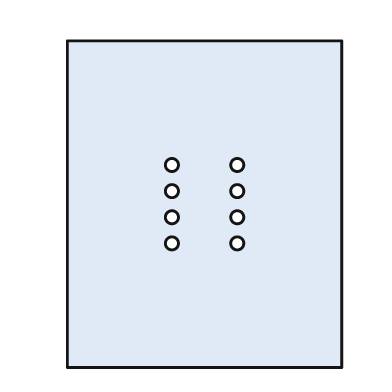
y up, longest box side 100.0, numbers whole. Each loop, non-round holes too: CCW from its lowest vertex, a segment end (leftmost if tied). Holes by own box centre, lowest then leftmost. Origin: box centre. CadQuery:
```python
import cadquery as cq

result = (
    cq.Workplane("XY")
    .moveTo(-42.0, -50.0)
    .lineTo(42.0, -50.0)
    .lineTo(42.0, 50.0)
    .lineTo(-42.0, 50.0)
    .close()
    .moveTo(-10.0, -12.0)
    .circle(2.0)
    .moveTo(10.0, -12.0)
    .circle(2.0)
    .moveTo(-10.0, -4.0)
    .circle(2.0)
    .moveTo(10.0, -4.0)
    .circle(2.0)
    .moveTo(-10.0, 4.0)
    .circle(2.0)
    .moveTo(10.0, 4.0)
    .circle(2.0)
    .moveTo(-10.0, 12.0)
    .circle(2.0)
    .moveTo(10.0, 12.0)
    .circle(2.0)
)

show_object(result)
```